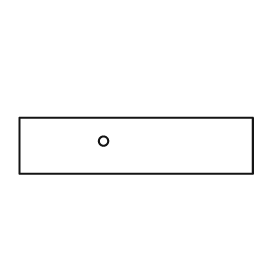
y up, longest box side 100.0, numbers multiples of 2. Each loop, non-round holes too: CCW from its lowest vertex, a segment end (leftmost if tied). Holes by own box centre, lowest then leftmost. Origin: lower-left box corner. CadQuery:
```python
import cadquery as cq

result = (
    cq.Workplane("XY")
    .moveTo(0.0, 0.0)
    .lineTo(100.0, 0.0)
    .lineTo(100.0, 24.0)
    .lineTo(0.0, 24.0)
    .close()
    .moveTo(36.0, 14.0)
    .circle(2.0)
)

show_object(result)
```